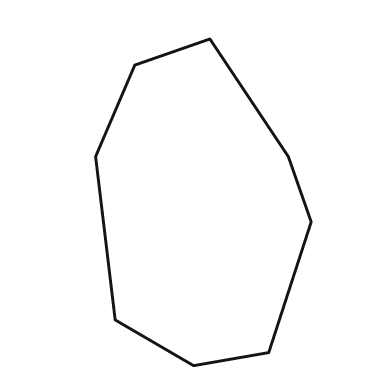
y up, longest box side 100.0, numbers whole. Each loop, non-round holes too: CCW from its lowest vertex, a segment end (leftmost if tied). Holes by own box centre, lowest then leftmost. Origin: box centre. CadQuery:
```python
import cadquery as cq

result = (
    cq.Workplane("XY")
    .moveTo(-3.0, -50.0)
    .lineTo(20.0, -46.0)
    .lineTo(33.0, -6.0)
    .lineTo(26.0, 14.0)
    .lineTo(2.0, 50.0)
    .lineTo(-21.0, 42.0)
    .lineTo(-33.0, 14.0)
    .lineTo(-27.0, -36.0)
    .close()
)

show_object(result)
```